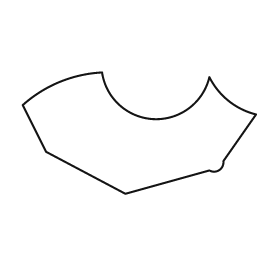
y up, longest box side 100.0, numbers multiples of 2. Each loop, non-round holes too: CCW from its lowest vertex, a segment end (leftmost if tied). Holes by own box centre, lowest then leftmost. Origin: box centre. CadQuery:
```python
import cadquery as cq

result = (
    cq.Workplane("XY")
    .moveTo(-6.0, -26.0)
    .lineTo(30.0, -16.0)
    .threePointArc((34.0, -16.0), (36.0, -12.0))
    .lineTo(50.0, 8.0)
    .threePointArc((38.0, 14.0), (30.0, 24.0))
    .threePointArc((6.0, 6.0), (-16.0, 26.0))
    .threePointArc((-34.0, 22.0), (-50.0, 12.0))
    .lineTo(-40.0, -8.0)
    .close()
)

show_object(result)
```